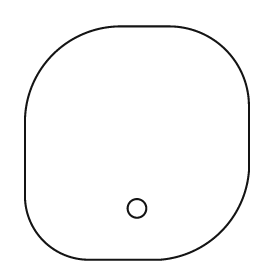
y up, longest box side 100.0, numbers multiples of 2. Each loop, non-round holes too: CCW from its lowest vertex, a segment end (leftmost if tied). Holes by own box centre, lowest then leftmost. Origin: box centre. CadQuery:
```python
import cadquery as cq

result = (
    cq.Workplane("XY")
    .moveTo(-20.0, -50.0)
    .lineTo(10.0, -50.0)
    .threePointArc((36.0, -38.0), (48.0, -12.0))
    .lineTo(48.0, 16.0)
    .threePointArc((38.0, 40.0), (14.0, 50.0))
    .lineTo(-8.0, 50.0)
    .threePointArc((-36.0, 38.0), (-48.0, 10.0))
    .lineTo(-48.0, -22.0)
    .threePointArc((-40.0, -42.0), (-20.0, -50.0))
    .close()
    .moveTo(0.0, -28.0)
    .circle(4.0)
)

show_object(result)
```